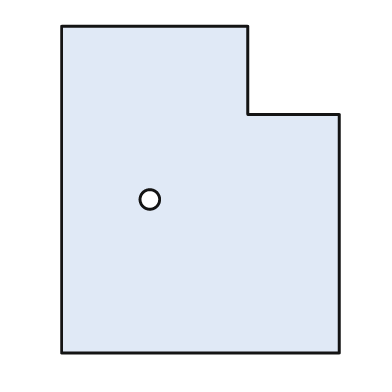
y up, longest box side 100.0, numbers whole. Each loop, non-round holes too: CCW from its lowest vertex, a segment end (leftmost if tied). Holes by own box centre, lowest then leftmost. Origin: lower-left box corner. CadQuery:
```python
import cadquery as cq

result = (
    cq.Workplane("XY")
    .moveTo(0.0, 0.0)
    .lineTo(85.0, 0.0)
    .lineTo(85.0, 73.0)
    .lineTo(57.0, 73.0)
    .lineTo(57.0, 100.0)
    .lineTo(0.0, 100.0)
    .close()
    .moveTo(27.0, 47.0)
    .circle(3.0)
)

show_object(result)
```